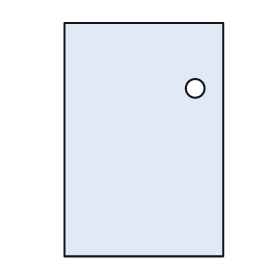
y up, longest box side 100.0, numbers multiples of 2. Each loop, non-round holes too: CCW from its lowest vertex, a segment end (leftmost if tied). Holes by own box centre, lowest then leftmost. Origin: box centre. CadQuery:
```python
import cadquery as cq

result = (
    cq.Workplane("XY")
    .moveTo(-34.0, -50.0)
    .lineTo(34.0, -50.0)
    .lineTo(34.0, 50.0)
    .lineTo(-34.0, 50.0)
    .close()
    .moveTo(22.0, 22.0)
    .circle(4.0)
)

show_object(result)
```